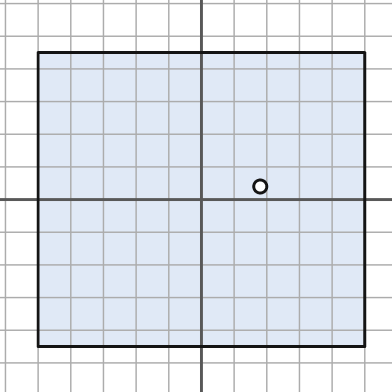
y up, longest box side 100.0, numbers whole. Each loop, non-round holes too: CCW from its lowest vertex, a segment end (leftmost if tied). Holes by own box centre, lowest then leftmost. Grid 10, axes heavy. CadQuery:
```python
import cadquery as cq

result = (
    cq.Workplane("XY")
    .moveTo(-50.0, -45.0)
    .lineTo(50.0, -45.0)
    .lineTo(50.0, 45.0)
    .lineTo(-50.0, 45.0)
    .close()
    .moveTo(18.0, 4.0)
    .circle(2.0)
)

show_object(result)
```